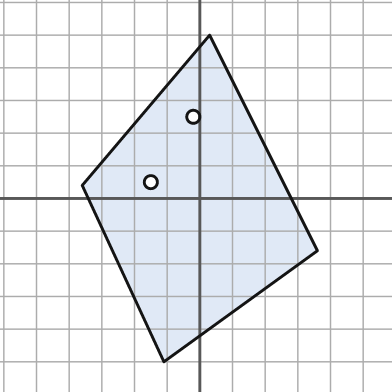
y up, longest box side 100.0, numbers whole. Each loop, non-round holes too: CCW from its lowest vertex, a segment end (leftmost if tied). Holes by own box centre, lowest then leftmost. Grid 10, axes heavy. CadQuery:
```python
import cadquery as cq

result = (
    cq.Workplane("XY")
    .moveTo(-11.0, -50.0)
    .lineTo(36.0, -16.0)
    .lineTo(3.0, 50.0)
    .lineTo(-36.0, 4.0)
    .close()
    .moveTo(-15.0, 5.0)
    .circle(2.0)
    .moveTo(-2.0, 25.0)
    .circle(2.0)
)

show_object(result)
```